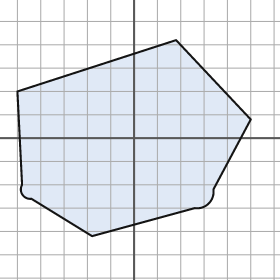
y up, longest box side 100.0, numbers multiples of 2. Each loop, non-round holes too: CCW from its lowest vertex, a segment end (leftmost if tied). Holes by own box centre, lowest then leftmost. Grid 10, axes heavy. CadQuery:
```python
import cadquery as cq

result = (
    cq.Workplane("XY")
    .moveTo(-18.0, -42.0)
    .lineTo(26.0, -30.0)
    .threePointArc((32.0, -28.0), (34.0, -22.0))
    .lineTo(50.0, 8.0)
    .lineTo(18.0, 42.0)
    .lineTo(-50.0, 20.0)
    .lineTo(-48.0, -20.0)
    .threePointArc((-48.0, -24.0), (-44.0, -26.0))
    .close()
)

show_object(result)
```